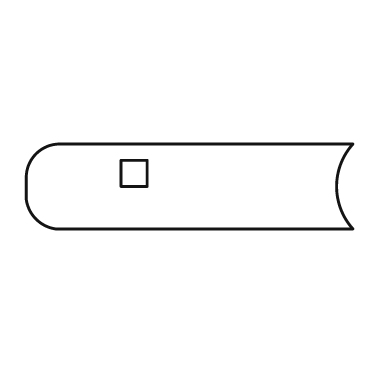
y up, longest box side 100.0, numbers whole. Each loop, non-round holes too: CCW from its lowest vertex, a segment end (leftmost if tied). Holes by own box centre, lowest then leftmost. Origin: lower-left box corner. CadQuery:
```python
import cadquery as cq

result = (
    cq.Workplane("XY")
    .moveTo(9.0, 0.0)
    .lineTo(100.0, 0.0)
    .threePointArc((95.0, 13.0), (100.0, 26.0))
    .lineTo(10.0, 26.0)
    .threePointArc((3.0, 23.0), (0.0, 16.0))
    .lineTo(0.0, 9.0)
    .threePointArc((3.0, 3.0), (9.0, 0.0))
    .close()
    .moveTo(29.0, 13.0)
    .lineTo(37.0, 13.0)
    .lineTo(37.0, 21.0)
    .lineTo(29.0, 21.0)
    .close()
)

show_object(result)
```